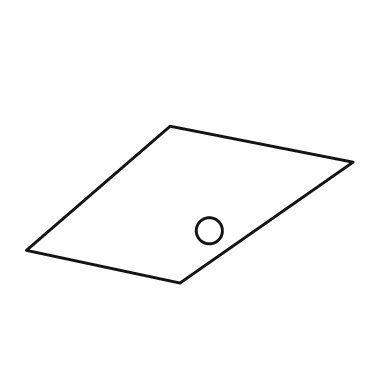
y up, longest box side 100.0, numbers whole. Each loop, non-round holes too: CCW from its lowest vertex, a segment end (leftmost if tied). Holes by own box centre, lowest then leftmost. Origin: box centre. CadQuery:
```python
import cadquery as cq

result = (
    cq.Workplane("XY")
    .moveTo(-3.0, -24.0)
    .lineTo(50.0, 13.0)
    .lineTo(-6.0, 24.0)
    .lineTo(-50.0, -14.0)
    .close()
    .moveTo(6.0, -8.0)
    .circle(4.0)
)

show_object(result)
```